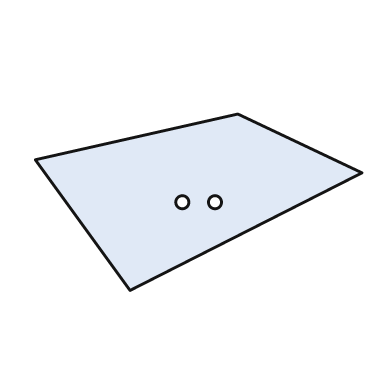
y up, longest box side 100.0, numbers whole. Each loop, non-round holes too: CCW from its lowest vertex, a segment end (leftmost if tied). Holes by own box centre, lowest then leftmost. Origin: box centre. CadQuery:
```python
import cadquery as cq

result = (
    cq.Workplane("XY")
    .moveTo(-21.0, -27.0)
    .lineTo(50.0, 9.0)
    .lineTo(12.0, 27.0)
    .lineTo(-50.0, 13.0)
    .close()
    .moveTo(-5.0, 0.0)
    .circle(2.0)
    .moveTo(5.0, 0.0)
    .circle(2.0)
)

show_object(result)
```